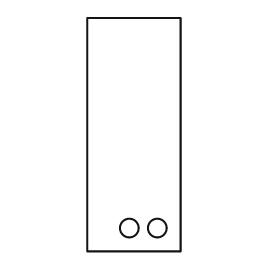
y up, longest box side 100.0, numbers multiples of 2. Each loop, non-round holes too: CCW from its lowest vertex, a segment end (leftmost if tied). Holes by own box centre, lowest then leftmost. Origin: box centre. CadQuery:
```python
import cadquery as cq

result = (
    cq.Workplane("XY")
    .moveTo(-20.0, -50.0)
    .lineTo(20.0, -50.0)
    .lineTo(20.0, 50.0)
    .lineTo(-20.0, 50.0)
    .close()
    .moveTo(-2.0, -40.0)
    .circle(4.0)
    .moveTo(10.0, -40.0)
    .circle(4.0)
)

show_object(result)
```